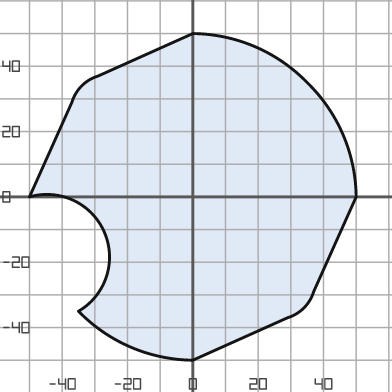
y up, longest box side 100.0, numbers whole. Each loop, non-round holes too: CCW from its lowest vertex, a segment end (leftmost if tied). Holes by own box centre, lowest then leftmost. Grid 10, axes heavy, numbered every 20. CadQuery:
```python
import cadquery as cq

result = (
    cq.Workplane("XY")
    .moveTo(0.0, -50.0)
    .lineTo(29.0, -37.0)
    .threePointArc((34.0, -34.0), (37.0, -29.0))
    .lineTo(50.0, 0.0)
    .threePointArc((46.0, 19.0), (35.0, 35.0))
    .threePointArc((19.0, 46.0), (0.0, 50.0))
    .lineTo(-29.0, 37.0)
    .threePointArc((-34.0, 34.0), (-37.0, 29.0))
    .lineTo(-50.0, 0.0)
    .threePointArc((-27.0, -11.0), (-35.0, -35.0))
    .threePointArc((-19.0, -46.0), (0.0, -50.0))
    .close()
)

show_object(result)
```